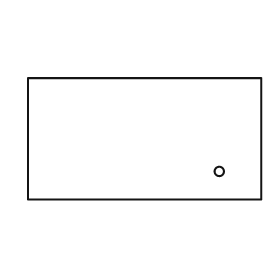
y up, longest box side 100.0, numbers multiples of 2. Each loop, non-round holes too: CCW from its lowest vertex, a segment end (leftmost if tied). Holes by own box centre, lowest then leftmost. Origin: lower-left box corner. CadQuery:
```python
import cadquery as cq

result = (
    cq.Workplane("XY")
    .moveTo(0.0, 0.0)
    .lineTo(100.0, 0.0)
    .lineTo(100.0, 52.0)
    .lineTo(0.0, 52.0)
    .close()
    .moveTo(82.0, 12.0)
    .circle(2.0)
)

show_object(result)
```